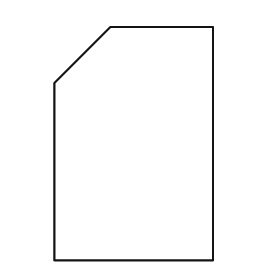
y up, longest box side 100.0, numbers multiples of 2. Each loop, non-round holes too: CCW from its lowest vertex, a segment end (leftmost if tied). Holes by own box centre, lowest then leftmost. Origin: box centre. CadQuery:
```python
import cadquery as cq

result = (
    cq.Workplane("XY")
    .moveTo(-34.0, -50.0)
    .lineTo(34.0, -50.0)
    .lineTo(34.0, 50.0)
    .lineTo(-10.0, 50.0)
    .lineTo(-34.0, 26.0)
    .close()
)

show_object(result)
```